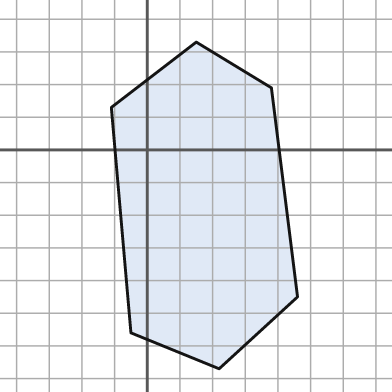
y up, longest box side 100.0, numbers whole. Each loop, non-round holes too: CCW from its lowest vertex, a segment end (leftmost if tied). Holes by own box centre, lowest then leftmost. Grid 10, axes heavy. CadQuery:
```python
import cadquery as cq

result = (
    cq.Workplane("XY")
    .moveTo(22.0, -67.0)
    .lineTo(46.0, -45.0)
    .lineTo(38.0, 19.0)
    .lineTo(15.0, 33.0)
    .lineTo(-11.0, 13.0)
    .lineTo(-5.0, -56.0)
    .close()
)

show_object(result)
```